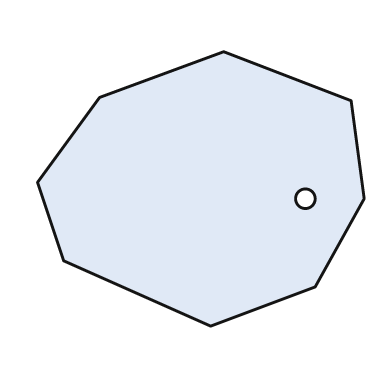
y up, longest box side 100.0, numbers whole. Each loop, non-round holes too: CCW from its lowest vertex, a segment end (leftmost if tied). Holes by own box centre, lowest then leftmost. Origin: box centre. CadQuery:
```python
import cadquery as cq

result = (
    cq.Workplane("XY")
    .moveTo(3.0, -42.0)
    .lineTo(35.0, -30.0)
    .lineTo(50.0, -3.0)
    .lineTo(46.0, 27.0)
    .lineTo(7.0, 42.0)
    .lineTo(-31.0, 28.0)
    .lineTo(-50.0, 2.0)
    .lineTo(-42.0, -22.0)
    .close()
    .moveTo(32.0, -3.0)
    .circle(3.0)
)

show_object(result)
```